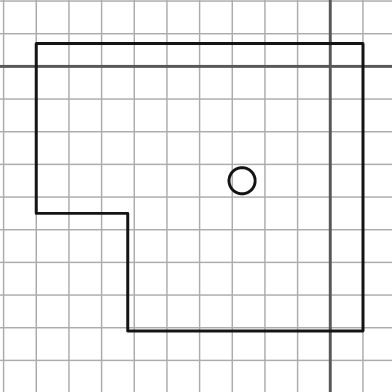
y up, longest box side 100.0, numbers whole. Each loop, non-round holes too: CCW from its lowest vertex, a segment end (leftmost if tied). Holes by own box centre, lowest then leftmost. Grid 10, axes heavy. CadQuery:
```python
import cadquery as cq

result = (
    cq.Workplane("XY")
    .moveTo(-62.0, -81.0)
    .lineTo(10.0, -81.0)
    .lineTo(10.0, 7.0)
    .lineTo(-90.0, 7.0)
    .lineTo(-90.0, -45.0)
    .lineTo(-62.0, -45.0)
    .close()
    .moveTo(-27.0, -35.0)
    .circle(4.0)
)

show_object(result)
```